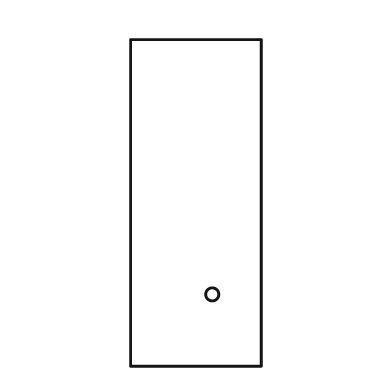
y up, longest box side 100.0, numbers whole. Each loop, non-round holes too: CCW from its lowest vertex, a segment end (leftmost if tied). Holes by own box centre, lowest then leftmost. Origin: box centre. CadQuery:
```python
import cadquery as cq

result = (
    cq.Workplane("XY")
    .moveTo(-20.0, -50.0)
    .lineTo(20.0, -50.0)
    .lineTo(20.0, 50.0)
    .lineTo(-20.0, 50.0)
    .close()
    .moveTo(5.0, -28.0)
    .circle(2.0)
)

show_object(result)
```